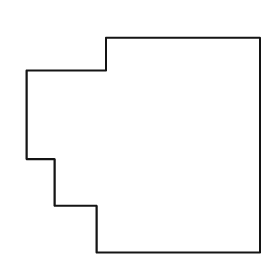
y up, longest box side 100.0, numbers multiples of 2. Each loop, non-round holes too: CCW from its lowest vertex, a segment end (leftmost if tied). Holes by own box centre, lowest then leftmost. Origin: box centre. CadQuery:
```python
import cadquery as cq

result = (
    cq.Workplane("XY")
    .moveTo(-20.0, -46.0)
    .lineTo(50.0, -46.0)
    .lineTo(50.0, 46.0)
    .lineTo(-16.0, 46.0)
    .lineTo(-16.0, 32.0)
    .lineTo(-50.0, 32.0)
    .lineTo(-50.0, -6.0)
    .lineTo(-38.0, -6.0)
    .lineTo(-38.0, -26.0)
    .lineTo(-20.0, -26.0)
    .close()
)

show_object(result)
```